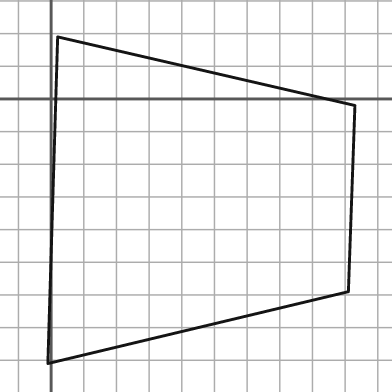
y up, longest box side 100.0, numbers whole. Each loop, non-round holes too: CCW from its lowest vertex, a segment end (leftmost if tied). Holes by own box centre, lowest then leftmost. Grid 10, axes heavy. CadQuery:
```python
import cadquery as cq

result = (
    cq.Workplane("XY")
    .moveTo(-1.0, -81.0)
    .lineTo(91.0, -59.0)
    .lineTo(93.0, -2.0)
    .lineTo(2.0, 19.0)
    .close()
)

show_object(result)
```